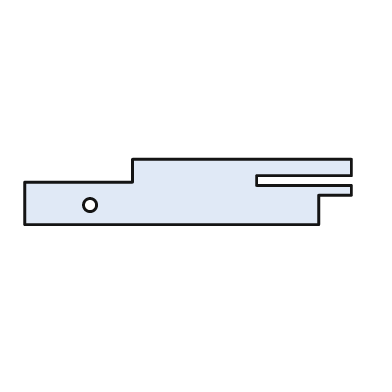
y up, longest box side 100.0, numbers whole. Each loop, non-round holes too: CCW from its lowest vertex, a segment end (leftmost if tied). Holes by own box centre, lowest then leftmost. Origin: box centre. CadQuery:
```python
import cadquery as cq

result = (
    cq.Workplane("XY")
    .moveTo(-50.0, -10.0)
    .lineTo(40.0, -10.0)
    .lineTo(40.0, -1.0)
    .lineTo(50.0, -1.0)
    .lineTo(50.0, 2.0)
    .lineTo(21.0, 2.0)
    .lineTo(21.0, 5.0)
    .lineTo(50.0, 5.0)
    .lineTo(50.0, 10.0)
    .lineTo(-17.0, 10.0)
    .lineTo(-17.0, 3.0)
    .lineTo(-50.0, 3.0)
    .close()
    .moveTo(-30.0, -4.0)
    .circle(2.0)
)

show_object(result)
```